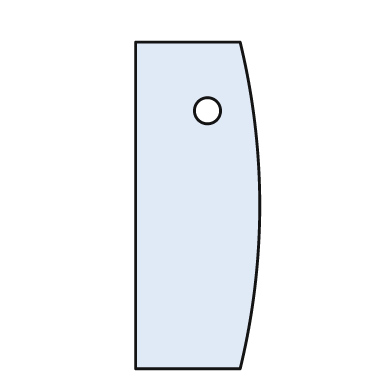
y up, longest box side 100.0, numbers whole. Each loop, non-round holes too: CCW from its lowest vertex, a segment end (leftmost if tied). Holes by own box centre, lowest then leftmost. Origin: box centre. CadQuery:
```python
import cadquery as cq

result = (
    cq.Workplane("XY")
    .moveTo(-19.0, -50.0)
    .lineTo(13.0, -50.0)
    .threePointArc((19.0, 0.0), (13.0, 50.0))
    .lineTo(-19.0, 50.0)
    .close()
    .moveTo(3.0, 29.0)
    .circle(4.0)
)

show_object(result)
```